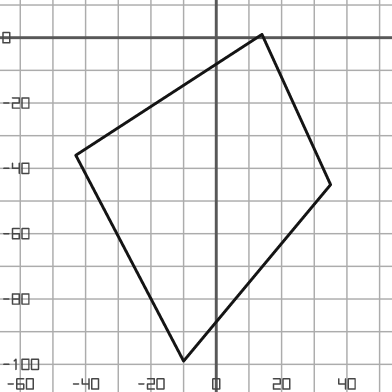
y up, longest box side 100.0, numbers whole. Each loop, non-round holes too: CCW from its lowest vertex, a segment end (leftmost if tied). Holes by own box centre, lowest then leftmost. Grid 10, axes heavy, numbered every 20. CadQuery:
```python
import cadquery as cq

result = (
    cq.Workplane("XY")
    .moveTo(-10.0, -99.0)
    .lineTo(35.0, -45.0)
    .lineTo(14.0, 1.0)
    .lineTo(-43.0, -36.0)
    .close()
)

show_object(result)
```